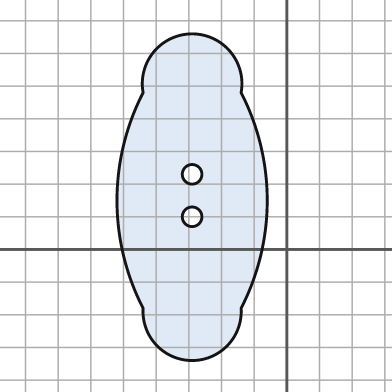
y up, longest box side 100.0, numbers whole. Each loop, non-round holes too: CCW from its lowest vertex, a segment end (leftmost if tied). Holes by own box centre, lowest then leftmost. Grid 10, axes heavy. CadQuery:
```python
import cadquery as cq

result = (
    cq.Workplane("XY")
    .moveTo(-44.0, -18.0)
    .threePointArc((-29.0, -34.0), (-14.0, -18.0))
    .threePointArc((-6.0, 15.0), (-14.0, 48.0))
    .threePointArc((-29.0, 66.0), (-44.0, 48.0))
    .threePointArc((-52.0, 15.0), (-44.0, -18.0))
    .close()
    .moveTo(-29.0, 10.0)
    .circle(3.0)
    .moveTo(-29.0, 23.0)
    .circle(3.0)
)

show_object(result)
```